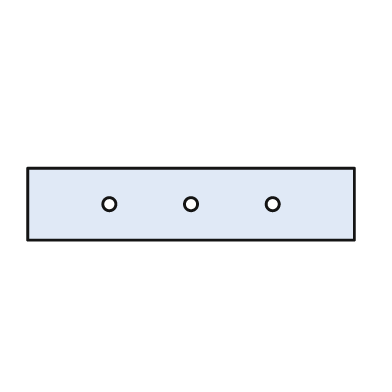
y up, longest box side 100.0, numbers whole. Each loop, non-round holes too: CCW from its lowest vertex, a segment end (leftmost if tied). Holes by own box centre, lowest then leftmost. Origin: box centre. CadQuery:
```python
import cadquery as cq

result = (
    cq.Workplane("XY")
    .moveTo(-50.0, -11.0)
    .lineTo(50.0, -11.0)
    .lineTo(50.0, 11.0)
    .lineTo(-50.0, 11.0)
    .close()
    .moveTo(-25.0, 0.0)
    .circle(2.0)
    .moveTo(0.0, 0.0)
    .circle(2.0)
    .moveTo(25.0, 0.0)
    .circle(2.0)
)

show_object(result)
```